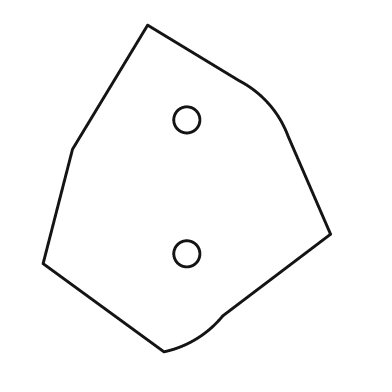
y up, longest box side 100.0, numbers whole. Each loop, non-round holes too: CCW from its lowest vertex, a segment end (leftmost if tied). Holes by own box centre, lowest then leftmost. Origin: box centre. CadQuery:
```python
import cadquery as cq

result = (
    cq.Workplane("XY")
    .moveTo(-7.0, -50.0)
    .threePointArc((3.0, -46.0), (11.0, -39.0))
    .lineTo(44.0, -14.0)
    .lineTo(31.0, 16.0)
    .threePointArc((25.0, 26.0), (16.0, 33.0))
    .lineTo(-12.0, 50.0)
    .lineTo(-35.0, 12.0)
    .lineTo(-44.0, -23.0)
    .close()
    .moveTo(0.0, -20.0)
    .circle(4.0)
    .moveTo(0.0, 21.0)
    .circle(4.0)
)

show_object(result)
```